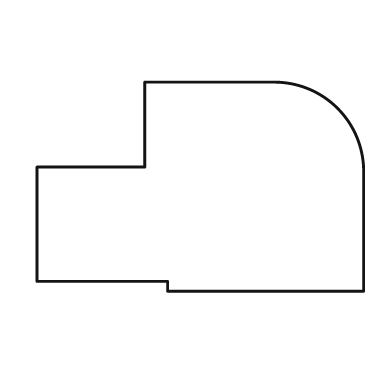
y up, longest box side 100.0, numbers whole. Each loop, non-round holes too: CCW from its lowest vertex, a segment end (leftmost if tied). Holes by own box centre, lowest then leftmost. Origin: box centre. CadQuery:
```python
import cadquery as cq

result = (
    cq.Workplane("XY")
    .moveTo(-10.0, -32.0)
    .lineTo(50.0, -32.0)
    .lineTo(50.0, 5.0)
    .threePointArc((42.0, 24.0), (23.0, 32.0))
    .lineTo(-17.0, 32.0)
    .lineTo(-17.0, 6.0)
    .lineTo(-50.0, 6.0)
    .lineTo(-50.0, -29.0)
    .lineTo(-10.0, -29.0)
    .close()
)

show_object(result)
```